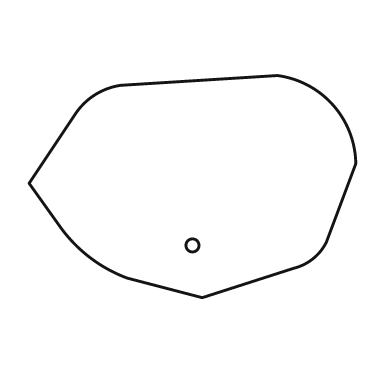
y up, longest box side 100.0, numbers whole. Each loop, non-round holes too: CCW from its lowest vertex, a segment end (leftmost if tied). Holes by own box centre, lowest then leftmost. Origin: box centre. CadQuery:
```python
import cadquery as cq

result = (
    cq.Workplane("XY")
    .moveTo(3.0, -34.0)
    .lineTo(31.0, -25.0)
    .threePointArc((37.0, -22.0), (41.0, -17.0))
    .lineTo(50.0, 7.0)
    .threePointArc((43.0, 25.0), (26.0, 34.0))
    .lineTo(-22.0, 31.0)
    .threePointArc((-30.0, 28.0), (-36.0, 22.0))
    .lineTo(-50.0, 1.0)
    .lineTo(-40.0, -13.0)
    .threePointArc((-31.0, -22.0), (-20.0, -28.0))
    .close()
    .moveTo(0.0, -18.0)
    .circle(2.0)
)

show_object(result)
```